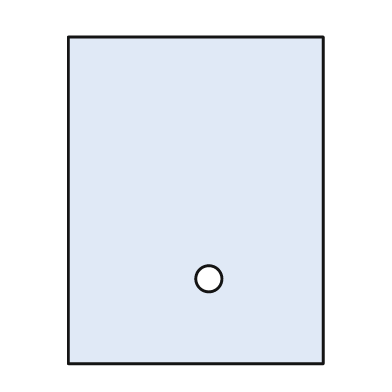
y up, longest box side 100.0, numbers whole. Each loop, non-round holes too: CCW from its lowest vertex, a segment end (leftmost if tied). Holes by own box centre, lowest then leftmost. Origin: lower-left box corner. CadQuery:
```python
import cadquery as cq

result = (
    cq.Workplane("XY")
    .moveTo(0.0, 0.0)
    .lineTo(78.0, 0.0)
    .lineTo(78.0, 100.0)
    .lineTo(0.0, 100.0)
    .close()
    .moveTo(43.0, 26.0)
    .circle(4.0)
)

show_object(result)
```